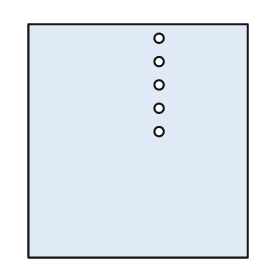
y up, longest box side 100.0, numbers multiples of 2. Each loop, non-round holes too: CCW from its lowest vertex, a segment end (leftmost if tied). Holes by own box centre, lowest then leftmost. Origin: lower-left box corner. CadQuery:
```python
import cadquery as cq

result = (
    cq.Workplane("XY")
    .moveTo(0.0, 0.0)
    .lineTo(94.0, 0.0)
    .lineTo(94.0, 100.0)
    .lineTo(0.0, 100.0)
    .close()
    .moveTo(56.0, 54.0)
    .circle(2.0)
    .moveTo(56.0, 64.0)
    .circle(2.0)
    .moveTo(56.0, 74.0)
    .circle(2.0)
    .moveTo(56.0, 84.0)
    .circle(2.0)
    .moveTo(56.0, 94.0)
    .circle(2.0)
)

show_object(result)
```